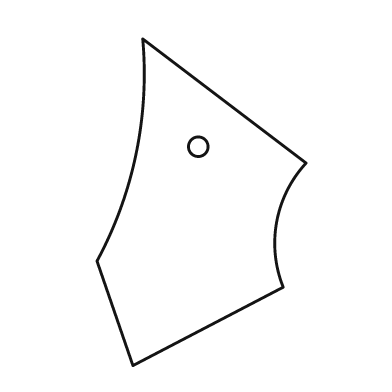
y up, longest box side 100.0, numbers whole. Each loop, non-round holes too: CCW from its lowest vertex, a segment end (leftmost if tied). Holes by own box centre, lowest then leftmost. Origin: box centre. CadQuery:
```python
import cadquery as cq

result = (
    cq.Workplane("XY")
    .moveTo(-21.0, -50.0)
    .lineTo(25.0, -26.0)
    .threePointArc((23.0, -6.0), (32.0, 12.0))
    .lineTo(-18.0, 50.0)
    .threePointArc((-20.0, 15.0), (-32.0, -18.0))
    .close()
    .moveTo(-1.0, 17.0)
    .circle(3.0)
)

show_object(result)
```